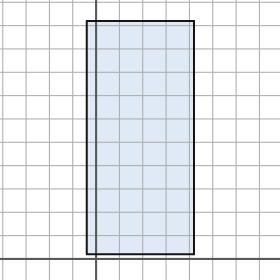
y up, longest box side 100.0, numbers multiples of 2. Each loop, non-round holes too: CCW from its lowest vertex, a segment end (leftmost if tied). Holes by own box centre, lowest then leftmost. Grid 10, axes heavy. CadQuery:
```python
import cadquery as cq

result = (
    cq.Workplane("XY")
    .moveTo(-4.0, 2.0)
    .lineTo(42.0, 2.0)
    .lineTo(42.0, 102.0)
    .lineTo(-4.0, 102.0)
    .close()
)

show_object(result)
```